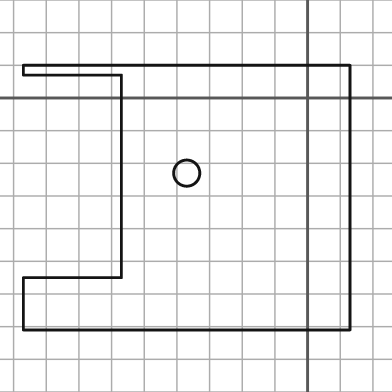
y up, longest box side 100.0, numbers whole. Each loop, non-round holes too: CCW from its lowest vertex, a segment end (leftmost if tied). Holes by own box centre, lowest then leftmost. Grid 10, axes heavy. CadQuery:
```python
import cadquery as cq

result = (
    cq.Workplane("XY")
    .moveTo(-87.0, -71.0)
    .lineTo(13.0, -71.0)
    .lineTo(13.0, 10.0)
    .lineTo(-87.0, 10.0)
    .lineTo(-87.0, 7.0)
    .lineTo(-57.0, 7.0)
    .lineTo(-57.0, -55.0)
    .lineTo(-87.0, -55.0)
    .close()
    .moveTo(-37.0, -23.0)
    .circle(4.0)
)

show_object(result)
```